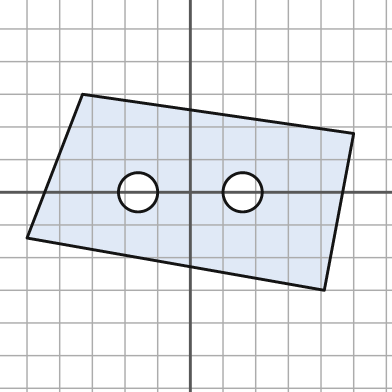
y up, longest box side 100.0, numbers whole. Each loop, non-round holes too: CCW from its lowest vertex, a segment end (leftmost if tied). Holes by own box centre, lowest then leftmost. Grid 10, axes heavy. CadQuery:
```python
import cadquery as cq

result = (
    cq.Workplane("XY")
    .moveTo(41.0, -30.0)
    .lineTo(50.0, 18.0)
    .lineTo(-33.0, 30.0)
    .lineTo(-50.0, -14.0)
    .close()
    .moveTo(-16.0, 0.0)
    .circle(6.0)
    .moveTo(16.0, 0.0)
    .circle(6.0)
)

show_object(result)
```